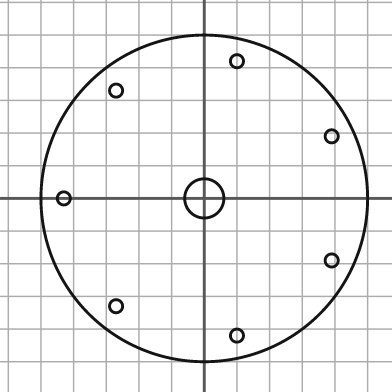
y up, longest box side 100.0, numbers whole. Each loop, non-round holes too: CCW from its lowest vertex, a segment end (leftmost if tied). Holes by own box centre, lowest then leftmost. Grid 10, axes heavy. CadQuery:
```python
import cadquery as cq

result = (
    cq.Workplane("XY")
    .moveTo(0.0, 0.0)
    .circle(50.0)
    .moveTo(10.0, -42.0)
    .circle(2.0)
    .moveTo(-27.0, -33.0)
    .circle(2.0)
    .moveTo(39.0, -19.0)
    .circle(2.0)
    .moveTo(-43.0, 0.0)
    .circle(2.0)
    .moveTo(0.0, 0.0)
    .circle(6.0)
    .moveTo(39.0, 19.0)
    .circle(2.0)
    .moveTo(-27.0, 33.0)
    .circle(2.0)
    .moveTo(10.0, 42.0)
    .circle(2.0)
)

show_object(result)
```